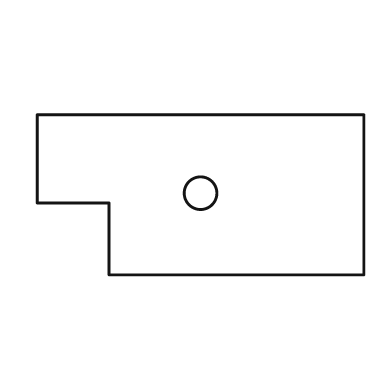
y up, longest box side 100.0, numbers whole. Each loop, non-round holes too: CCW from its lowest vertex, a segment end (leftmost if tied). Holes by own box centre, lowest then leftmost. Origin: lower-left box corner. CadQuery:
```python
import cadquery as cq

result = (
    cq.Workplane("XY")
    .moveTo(22.0, 0.0)
    .lineTo(100.0, 0.0)
    .lineTo(100.0, 49.0)
    .lineTo(0.0, 49.0)
    .lineTo(0.0, 22.0)
    .lineTo(22.0, 22.0)
    .close()
    .moveTo(50.0, 25.0)
    .circle(5.0)
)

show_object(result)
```